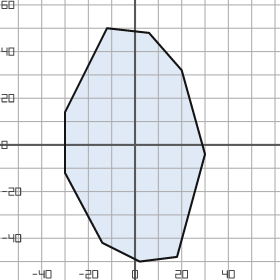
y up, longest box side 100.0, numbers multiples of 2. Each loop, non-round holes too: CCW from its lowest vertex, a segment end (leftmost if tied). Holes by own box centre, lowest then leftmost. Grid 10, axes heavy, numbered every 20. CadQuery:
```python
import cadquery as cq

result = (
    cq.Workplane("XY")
    .moveTo(2.0, -50.0)
    .lineTo(18.0, -48.0)
    .lineTo(30.0, -4.0)
    .lineTo(20.0, 32.0)
    .lineTo(6.0, 48.0)
    .lineTo(-12.0, 50.0)
    .lineTo(-30.0, 14.0)
    .lineTo(-30.0, -12.0)
    .lineTo(-14.0, -42.0)
    .close()
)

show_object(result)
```